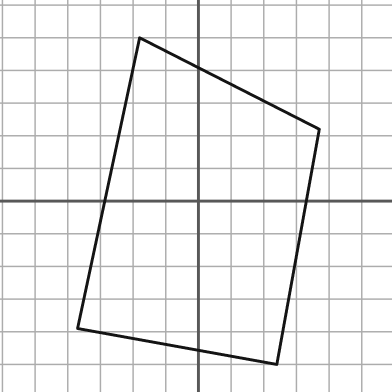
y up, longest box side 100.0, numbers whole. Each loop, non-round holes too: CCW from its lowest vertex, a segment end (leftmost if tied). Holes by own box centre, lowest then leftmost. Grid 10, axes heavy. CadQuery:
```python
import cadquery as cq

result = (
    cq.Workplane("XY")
    .moveTo(24.0, -50.0)
    .lineTo(37.0, 22.0)
    .lineTo(-18.0, 50.0)
    .lineTo(-37.0, -39.0)
    .close()
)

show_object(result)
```